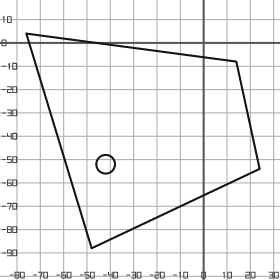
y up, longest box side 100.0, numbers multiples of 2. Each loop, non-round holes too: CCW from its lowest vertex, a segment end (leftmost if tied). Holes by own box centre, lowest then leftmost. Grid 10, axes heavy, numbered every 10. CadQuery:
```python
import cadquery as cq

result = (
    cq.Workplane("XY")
    .moveTo(-48.0, -88.0)
    .lineTo(24.0, -54.0)
    .lineTo(14.0, -8.0)
    .lineTo(-76.0, 4.0)
    .close()
    .moveTo(-42.0, -52.0)
    .circle(4.0)
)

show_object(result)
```